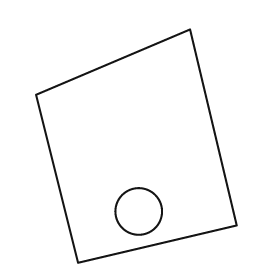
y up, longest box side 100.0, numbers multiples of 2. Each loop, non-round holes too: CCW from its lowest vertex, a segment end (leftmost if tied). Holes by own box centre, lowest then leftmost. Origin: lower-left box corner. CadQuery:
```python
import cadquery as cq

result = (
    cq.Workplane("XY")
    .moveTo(18.0, 0.0)
    .lineTo(86.0, 16.0)
    .lineTo(66.0, 100.0)
    .lineTo(0.0, 72.0)
    .close()
    .moveTo(44.0, 22.0)
    .circle(10.0)
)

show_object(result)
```